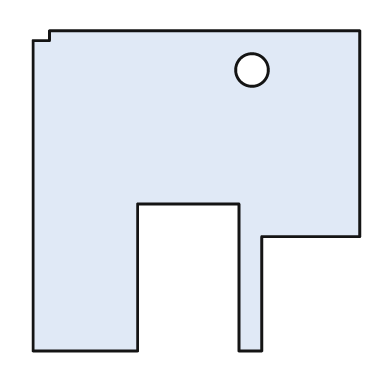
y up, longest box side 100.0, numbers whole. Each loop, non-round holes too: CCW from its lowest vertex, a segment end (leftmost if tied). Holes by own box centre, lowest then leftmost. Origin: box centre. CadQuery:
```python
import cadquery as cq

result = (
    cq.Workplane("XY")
    .moveTo(-50.0, -49.0)
    .lineTo(-18.0, -49.0)
    .lineTo(-18.0, -4.0)
    .lineTo(13.0, -4.0)
    .lineTo(13.0, -49.0)
    .lineTo(20.0, -49.0)
    .lineTo(20.0, -14.0)
    .lineTo(50.0, -14.0)
    .lineTo(50.0, 49.0)
    .lineTo(-45.0, 49.0)
    .lineTo(-45.0, 46.0)
    .lineTo(-50.0, 46.0)
    .close()
    .moveTo(17.0, 37.0)
    .circle(5.0)
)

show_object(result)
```